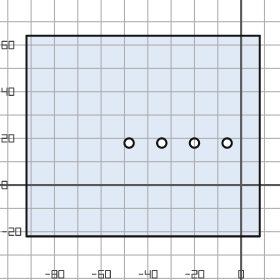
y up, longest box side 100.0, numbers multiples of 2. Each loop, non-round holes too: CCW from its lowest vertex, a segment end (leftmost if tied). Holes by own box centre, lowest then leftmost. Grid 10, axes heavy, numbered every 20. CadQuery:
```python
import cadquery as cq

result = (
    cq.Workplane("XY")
    .moveTo(-92.0, -22.0)
    .lineTo(8.0, -22.0)
    .lineTo(8.0, 64.0)
    .lineTo(-92.0, 64.0)
    .close()
    .moveTo(-48.0, 18.0)
    .circle(2.0)
    .moveTo(-34.0, 18.0)
    .circle(2.0)
    .moveTo(-20.0, 18.0)
    .circle(2.0)
    .moveTo(-6.0, 18.0)
    .circle(2.0)
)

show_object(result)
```